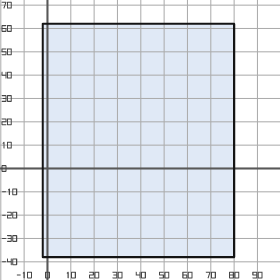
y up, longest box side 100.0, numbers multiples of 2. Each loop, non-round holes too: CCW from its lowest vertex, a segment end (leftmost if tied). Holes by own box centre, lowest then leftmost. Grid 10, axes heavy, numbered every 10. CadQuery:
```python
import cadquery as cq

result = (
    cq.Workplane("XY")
    .moveTo(-2.0, -38.0)
    .lineTo(80.0, -38.0)
    .lineTo(80.0, 62.0)
    .lineTo(-2.0, 62.0)
    .close()
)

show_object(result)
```